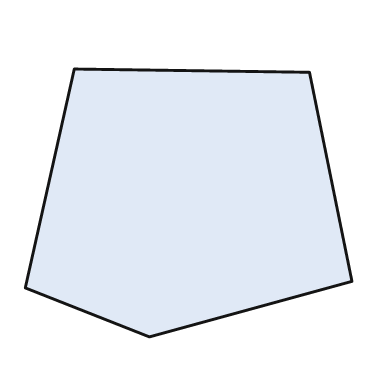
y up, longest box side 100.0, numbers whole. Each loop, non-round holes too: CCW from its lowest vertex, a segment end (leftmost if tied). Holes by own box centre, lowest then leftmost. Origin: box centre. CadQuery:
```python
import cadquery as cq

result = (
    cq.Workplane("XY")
    .moveTo(-12.0, -41.0)
    .lineTo(50.0, -24.0)
    .lineTo(37.0, 40.0)
    .lineTo(-35.0, 41.0)
    .lineTo(-50.0, -26.0)
    .close()
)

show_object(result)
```